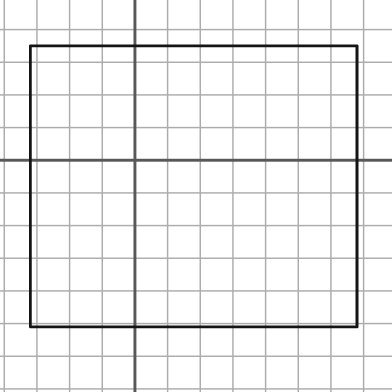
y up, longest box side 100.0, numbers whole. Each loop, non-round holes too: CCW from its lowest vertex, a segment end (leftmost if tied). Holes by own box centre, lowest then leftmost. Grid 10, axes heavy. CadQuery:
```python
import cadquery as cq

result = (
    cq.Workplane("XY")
    .moveTo(-32.0, -51.0)
    .lineTo(68.0, -51.0)
    .lineTo(68.0, 35.0)
    .lineTo(-32.0, 35.0)
    .close()
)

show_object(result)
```